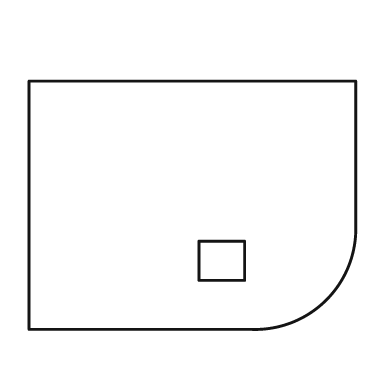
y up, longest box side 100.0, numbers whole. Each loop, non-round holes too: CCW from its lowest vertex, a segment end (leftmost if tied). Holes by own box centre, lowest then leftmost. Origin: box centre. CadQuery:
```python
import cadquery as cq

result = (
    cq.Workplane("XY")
    .moveTo(-50.0, -38.0)
    .lineTo(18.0, -38.0)
    .threePointArc((41.0, -29.0), (50.0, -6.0))
    .lineTo(50.0, 38.0)
    .lineTo(-50.0, 38.0)
    .close()
    .moveTo(2.0, -23.0)
    .lineTo(16.0, -23.0)
    .lineTo(16.0, -11.0)
    .lineTo(2.0, -11.0)
    .close()
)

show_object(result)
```